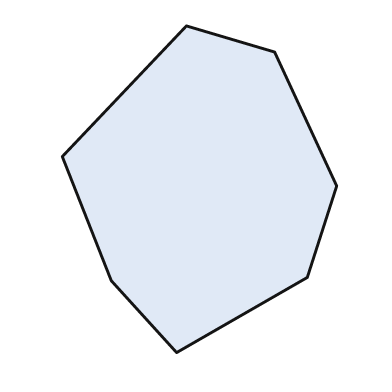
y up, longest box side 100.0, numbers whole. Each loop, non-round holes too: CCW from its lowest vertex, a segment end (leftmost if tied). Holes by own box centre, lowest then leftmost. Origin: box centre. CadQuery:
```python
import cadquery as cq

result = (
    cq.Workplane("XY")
    .moveTo(-7.0, -50.0)
    .lineTo(33.0, -27.0)
    .lineTo(42.0, 1.0)
    .lineTo(23.0, 42.0)
    .lineTo(-4.0, 50.0)
    .lineTo(-42.0, 10.0)
    .lineTo(-27.0, -28.0)
    .close()
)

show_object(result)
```